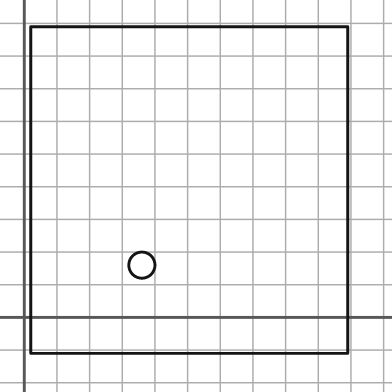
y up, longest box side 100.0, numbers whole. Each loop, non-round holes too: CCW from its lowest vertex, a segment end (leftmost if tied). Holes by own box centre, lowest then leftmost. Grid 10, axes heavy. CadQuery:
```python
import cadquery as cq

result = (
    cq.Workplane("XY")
    .moveTo(2.0, -11.0)
    .lineTo(99.0, -11.0)
    .lineTo(99.0, 89.0)
    .lineTo(2.0, 89.0)
    .close()
    .moveTo(36.0, 16.0)
    .circle(4.0)
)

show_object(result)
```